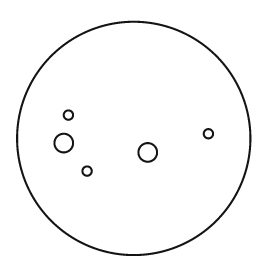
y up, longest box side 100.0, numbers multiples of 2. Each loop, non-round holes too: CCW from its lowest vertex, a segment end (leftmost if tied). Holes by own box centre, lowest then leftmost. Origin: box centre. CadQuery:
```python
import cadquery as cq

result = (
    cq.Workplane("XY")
    .moveTo(0.0, 0.0)
    .circle(50.0)
    .moveTo(-20.0, -14.0)
    .circle(2.0)
    .moveTo(6.0, -6.0)
    .circle(4.0)
    .moveTo(-30.0, -2.0)
    .circle(4.0)
    .moveTo(32.0, 2.0)
    .circle(2.0)
    .moveTo(-28.0, 10.0)
    .circle(2.0)
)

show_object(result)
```